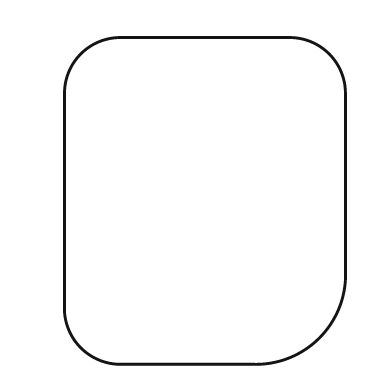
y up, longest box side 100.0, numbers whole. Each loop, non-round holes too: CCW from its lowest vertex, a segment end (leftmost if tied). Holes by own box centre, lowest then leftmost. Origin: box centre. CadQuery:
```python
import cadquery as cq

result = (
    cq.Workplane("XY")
    .moveTo(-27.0, -50.0)
    .lineTo(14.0, -50.0)
    .threePointArc((35.0, -42.0), (43.0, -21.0))
    .lineTo(43.0, 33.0)
    .threePointArc((38.0, 45.0), (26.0, 50.0))
    .lineTo(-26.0, 50.0)
    .threePointArc((-38.0, 45.0), (-43.0, 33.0))
    .lineTo(-43.0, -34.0)
    .threePointArc((-38.0, -45.0), (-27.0, -50.0))
    .close()
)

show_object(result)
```